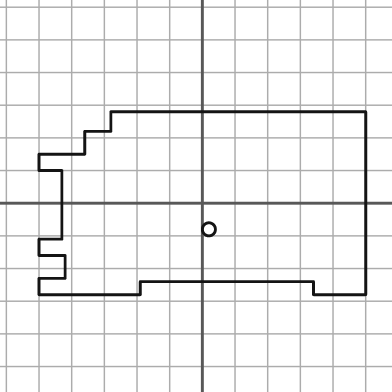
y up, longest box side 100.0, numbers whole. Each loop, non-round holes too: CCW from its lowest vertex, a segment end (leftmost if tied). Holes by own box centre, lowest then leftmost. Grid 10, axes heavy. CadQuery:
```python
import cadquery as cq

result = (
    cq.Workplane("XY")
    .moveTo(-50.0, -28.0)
    .lineTo(-19.0, -28.0)
    .lineTo(-19.0, -24.0)
    .lineTo(34.0, -24.0)
    .lineTo(34.0, -28.0)
    .lineTo(50.0, -28.0)
    .lineTo(50.0, 28.0)
    .lineTo(-28.0, 28.0)
    .lineTo(-28.0, 22.0)
    .lineTo(-36.0, 22.0)
    .lineTo(-36.0, 15.0)
    .lineTo(-50.0, 15.0)
    .lineTo(-50.0, 10.0)
    .lineTo(-43.0, 10.0)
    .lineTo(-43.0, -11.0)
    .lineTo(-50.0, -11.0)
    .lineTo(-50.0, -16.0)
    .lineTo(-42.0, -16.0)
    .lineTo(-42.0, -23.0)
    .lineTo(-50.0, -23.0)
    .close()
    .moveTo(2.0, -8.0)
    .circle(2.0)
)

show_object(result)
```